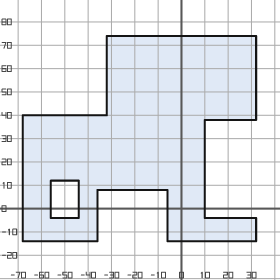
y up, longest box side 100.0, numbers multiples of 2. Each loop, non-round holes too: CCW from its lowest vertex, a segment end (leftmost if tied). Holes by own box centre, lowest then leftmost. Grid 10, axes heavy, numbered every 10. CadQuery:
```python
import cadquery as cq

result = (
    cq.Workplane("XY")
    .moveTo(-68.0, -14.0)
    .lineTo(-36.0, -14.0)
    .lineTo(-36.0, 8.0)
    .lineTo(-6.0, 8.0)
    .lineTo(-6.0, -14.0)
    .lineTo(32.0, -14.0)
    .lineTo(32.0, -4.0)
    .lineTo(10.0, -4.0)
    .lineTo(10.0, 38.0)
    .lineTo(32.0, 38.0)
    .lineTo(32.0, 74.0)
    .lineTo(-32.0, 74.0)
    .lineTo(-32.0, 40.0)
    .lineTo(-68.0, 40.0)
    .close()
    .moveTo(-56.0, -4.0)
    .lineTo(-44.0, -4.0)
    .lineTo(-44.0, 12.0)
    .lineTo(-56.0, 12.0)
    .close()
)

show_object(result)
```